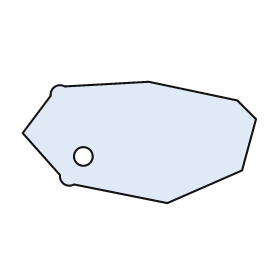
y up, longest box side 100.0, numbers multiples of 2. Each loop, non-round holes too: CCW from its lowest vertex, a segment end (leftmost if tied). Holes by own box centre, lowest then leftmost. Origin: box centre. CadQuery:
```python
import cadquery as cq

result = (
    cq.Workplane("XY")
    .moveTo(12.0, -26.0)
    .lineTo(44.0, -12.0)
    .lineTo(50.0, 10.0)
    .lineTo(42.0, 18.0)
    .lineTo(4.0, 26.0)
    .lineTo(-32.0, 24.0)
    .threePointArc((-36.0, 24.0), (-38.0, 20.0))
    .lineTo(-50.0, 4.0)
    .lineTo(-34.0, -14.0)
    .threePointArc((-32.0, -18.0), (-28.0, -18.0))
    .close()
    .moveTo(-24.0, -6.0)
    .circle(4.0)
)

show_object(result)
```